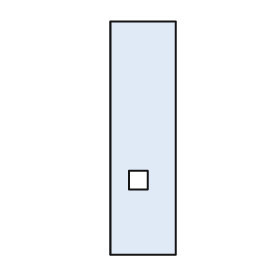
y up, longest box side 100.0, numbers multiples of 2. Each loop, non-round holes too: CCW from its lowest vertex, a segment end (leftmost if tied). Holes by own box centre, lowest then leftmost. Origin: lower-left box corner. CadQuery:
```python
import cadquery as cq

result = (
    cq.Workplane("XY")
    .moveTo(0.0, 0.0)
    .lineTo(28.0, 0.0)
    .lineTo(28.0, 100.0)
    .lineTo(0.0, 100.0)
    .close()
    .moveTo(8.0, 28.0)
    .lineTo(16.0, 28.0)
    .lineTo(16.0, 36.0)
    .lineTo(8.0, 36.0)
    .close()
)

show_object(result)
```